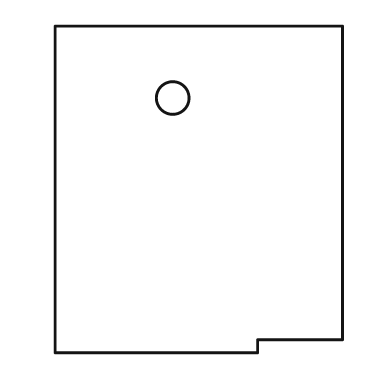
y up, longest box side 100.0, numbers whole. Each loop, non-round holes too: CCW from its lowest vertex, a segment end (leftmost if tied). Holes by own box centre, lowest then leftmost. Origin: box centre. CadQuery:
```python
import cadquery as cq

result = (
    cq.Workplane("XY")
    .moveTo(-44.0, -50.0)
    .lineTo(18.0, -50.0)
    .lineTo(18.0, -46.0)
    .lineTo(44.0, -46.0)
    .lineTo(44.0, 50.0)
    .lineTo(-44.0, 50.0)
    .close()
    .moveTo(-8.0, 28.0)
    .circle(5.0)
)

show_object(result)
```